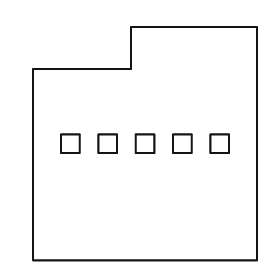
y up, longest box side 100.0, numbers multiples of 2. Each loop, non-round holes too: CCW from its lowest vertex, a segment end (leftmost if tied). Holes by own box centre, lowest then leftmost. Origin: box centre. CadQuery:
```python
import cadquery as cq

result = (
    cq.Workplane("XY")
    .moveTo(-48.0, -50.0)
    .lineTo(48.0, -50.0)
    .lineTo(48.0, 50.0)
    .lineTo(-6.0, 50.0)
    .lineTo(-6.0, 32.0)
    .lineTo(-48.0, 32.0)
    .close()
    .moveTo(-36.0, -4.0)
    .lineTo(-28.0, -4.0)
    .lineTo(-28.0, 4.0)
    .lineTo(-36.0, 4.0)
    .close()
    .moveTo(-20.0, -4.0)
    .lineTo(-12.0, -4.0)
    .lineTo(-12.0, 4.0)
    .lineTo(-20.0, 4.0)
    .close()
    .moveTo(-4.0, -4.0)
    .lineTo(4.0, -4.0)
    .lineTo(4.0, 4.0)
    .lineTo(-4.0, 4.0)
    .close()
    .moveTo(12.0, -4.0)
    .lineTo(20.0, -4.0)
    .lineTo(20.0, 4.0)
    .lineTo(12.0, 4.0)
    .close()
    .moveTo(28.0, -4.0)
    .lineTo(36.0, -4.0)
    .lineTo(36.0, 4.0)
    .lineTo(28.0, 4.0)
    .close()
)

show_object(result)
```